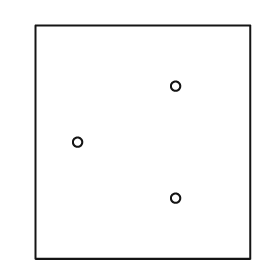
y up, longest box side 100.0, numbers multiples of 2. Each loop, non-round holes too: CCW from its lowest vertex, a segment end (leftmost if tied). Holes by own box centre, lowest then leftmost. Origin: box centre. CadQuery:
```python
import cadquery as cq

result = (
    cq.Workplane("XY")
    .moveTo(-46.0, -50.0)
    .lineTo(46.0, -50.0)
    .lineTo(46.0, 50.0)
    .lineTo(-46.0, 50.0)
    .close()
    .moveTo(14.0, -24.0)
    .circle(2.0)
    .moveTo(-28.0, 0.0)
    .circle(2.0)
    .moveTo(14.0, 24.0)
    .circle(2.0)
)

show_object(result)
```